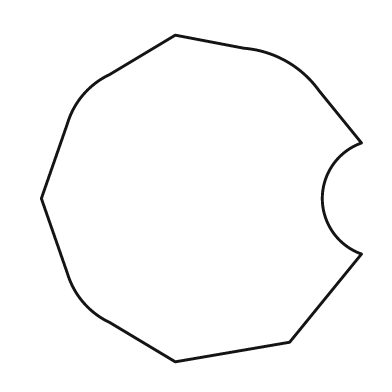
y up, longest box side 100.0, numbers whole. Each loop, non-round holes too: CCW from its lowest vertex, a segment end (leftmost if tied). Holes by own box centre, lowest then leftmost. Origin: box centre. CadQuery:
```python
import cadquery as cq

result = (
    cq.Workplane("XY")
    .moveTo(-8.0, -50.0)
    .lineTo(27.0, -44.0)
    .lineTo(49.0, -17.0)
    .threePointArc((37.0, 0.0), (49.0, 17.0))
    .lineTo(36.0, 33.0)
    .threePointArc((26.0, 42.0), (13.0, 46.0))
    .lineTo(-8.0, 50.0)
    .lineTo(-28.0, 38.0)
    .threePointArc((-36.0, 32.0), (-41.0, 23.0))
    .lineTo(-49.0, 0.0)
    .lineTo(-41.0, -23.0)
    .threePointArc((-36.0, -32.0), (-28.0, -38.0))
    .close()
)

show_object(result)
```